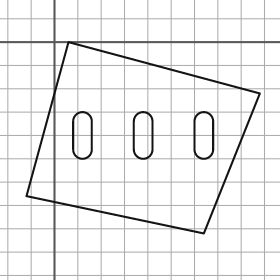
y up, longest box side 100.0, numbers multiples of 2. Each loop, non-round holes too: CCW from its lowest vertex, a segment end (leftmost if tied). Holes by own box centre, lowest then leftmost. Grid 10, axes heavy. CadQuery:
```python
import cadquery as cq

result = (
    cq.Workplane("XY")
    .moveTo(64.0, -82.0)
    .lineTo(88.0, -22.0)
    .lineTo(6.0, 0.0)
    .lineTo(-12.0, -66.0)
    .close()
    .moveTo(8.0, -46.0)
    .threePointArc((12.0, -50.0), (16.0, -46.0))
    .lineTo(16.0, -34.0)
    .threePointArc((12.0, -30.0), (8.0, -34.0))
    .close()
    .moveTo(34.0, -46.0)
    .threePointArc((38.0, -50.0), (42.0, -46.0))
    .lineTo(42.0, -34.0)
    .threePointArc((38.0, -30.0), (34.0, -34.0))
    .close()
    .moveTo(60.0, -46.0)
    .threePointArc((64.0, -50.0), (68.0, -46.0))
    .lineTo(68.0, -34.0)
    .threePointArc((64.0, -30.0), (60.0, -34.0))
    .close()
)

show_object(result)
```